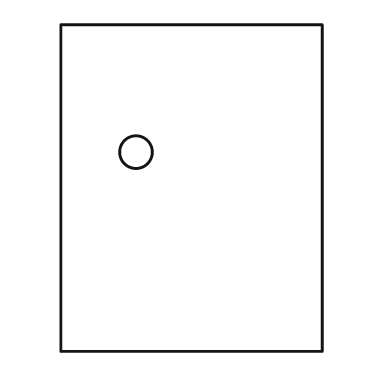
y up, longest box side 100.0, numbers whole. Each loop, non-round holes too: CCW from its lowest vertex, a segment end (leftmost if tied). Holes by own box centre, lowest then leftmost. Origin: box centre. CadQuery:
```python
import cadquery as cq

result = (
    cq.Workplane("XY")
    .moveTo(-40.0, -50.0)
    .lineTo(40.0, -50.0)
    .lineTo(40.0, 50.0)
    .lineTo(-40.0, 50.0)
    .close()
    .moveTo(-17.0, 11.0)
    .circle(5.0)
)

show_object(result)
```